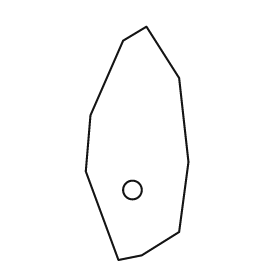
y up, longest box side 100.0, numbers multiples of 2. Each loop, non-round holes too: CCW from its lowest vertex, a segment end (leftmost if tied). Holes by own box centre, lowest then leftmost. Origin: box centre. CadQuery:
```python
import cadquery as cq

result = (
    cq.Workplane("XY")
    .moveTo(-8.0, -50.0)
    .lineTo(2.0, -48.0)
    .lineTo(18.0, -38.0)
    .lineTo(22.0, -8.0)
    .lineTo(18.0, 28.0)
    .lineTo(4.0, 50.0)
    .lineTo(-6.0, 44.0)
    .lineTo(-20.0, 12.0)
    .lineTo(-22.0, -12.0)
    .close()
    .moveTo(-2.0, -20.0)
    .circle(4.0)
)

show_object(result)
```